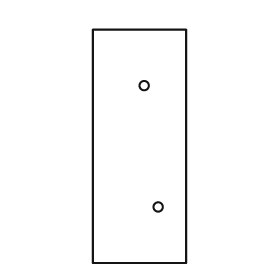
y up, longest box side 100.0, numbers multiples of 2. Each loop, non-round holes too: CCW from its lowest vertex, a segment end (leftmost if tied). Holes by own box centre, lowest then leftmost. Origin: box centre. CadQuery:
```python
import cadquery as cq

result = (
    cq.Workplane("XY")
    .moveTo(-20.0, -50.0)
    .lineTo(20.0, -50.0)
    .lineTo(20.0, 50.0)
    .lineTo(-20.0, 50.0)
    .close()
    .moveTo(8.0, -26.0)
    .circle(2.0)
    .moveTo(2.0, 26.0)
    .circle(2.0)
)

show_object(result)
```